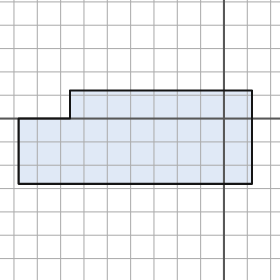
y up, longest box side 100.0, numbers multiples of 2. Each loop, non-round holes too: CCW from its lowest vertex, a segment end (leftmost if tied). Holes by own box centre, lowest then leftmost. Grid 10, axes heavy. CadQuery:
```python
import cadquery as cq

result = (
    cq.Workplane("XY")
    .moveTo(-88.0, -28.0)
    .lineTo(12.0, -28.0)
    .lineTo(12.0, 12.0)
    .lineTo(-66.0, 12.0)
    .lineTo(-66.0, 0.0)
    .lineTo(-88.0, 0.0)
    .close()
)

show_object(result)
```